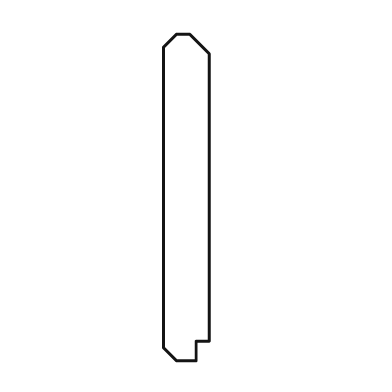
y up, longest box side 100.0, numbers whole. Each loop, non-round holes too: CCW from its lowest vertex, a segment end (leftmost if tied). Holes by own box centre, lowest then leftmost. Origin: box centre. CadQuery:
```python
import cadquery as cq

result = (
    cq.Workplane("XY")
    .moveTo(-3.0, -50.0)
    .lineTo(3.0, -50.0)
    .lineTo(3.0, -44.0)
    .lineTo(7.0, -44.0)
    .lineTo(7.0, 44.0)
    .lineTo(1.0, 50.0)
    .lineTo(-3.0, 50.0)
    .lineTo(-7.0, 46.0)
    .lineTo(-7.0, -46.0)
    .close()
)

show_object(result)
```